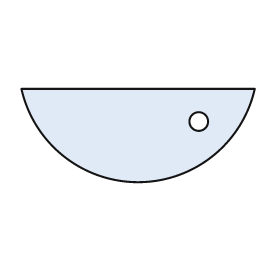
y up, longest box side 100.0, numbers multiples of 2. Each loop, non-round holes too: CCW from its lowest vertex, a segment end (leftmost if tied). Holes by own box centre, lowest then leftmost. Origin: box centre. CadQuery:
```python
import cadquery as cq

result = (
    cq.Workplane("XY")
    .moveTo(-50.0, 20.0)
    .threePointArc((0.0, -20.0), (50.0, 20.0))
    .close()
    .moveTo(26.0, 6.0)
    .circle(4.0)
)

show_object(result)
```